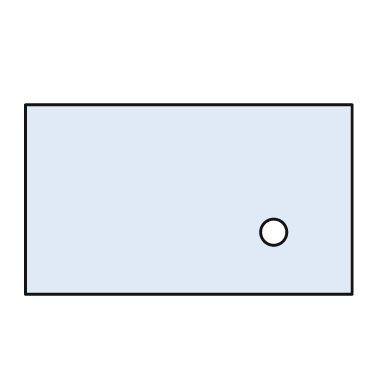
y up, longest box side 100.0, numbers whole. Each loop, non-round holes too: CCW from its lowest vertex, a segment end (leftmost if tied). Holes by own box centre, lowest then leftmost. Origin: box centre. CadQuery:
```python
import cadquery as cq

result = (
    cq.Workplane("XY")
    .moveTo(-50.0, -29.0)
    .lineTo(50.0, -29.0)
    .lineTo(50.0, 29.0)
    .lineTo(-50.0, 29.0)
    .close()
    .moveTo(26.0, -10.0)
    .circle(4.0)
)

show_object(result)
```